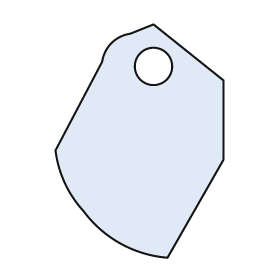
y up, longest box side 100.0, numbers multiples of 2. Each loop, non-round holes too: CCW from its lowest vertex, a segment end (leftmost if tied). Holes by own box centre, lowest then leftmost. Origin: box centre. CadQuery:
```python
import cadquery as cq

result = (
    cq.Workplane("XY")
    .moveTo(12.0, -50.0)
    .lineTo(36.0, -8.0)
    .lineTo(36.0, 26.0)
    .lineTo(6.0, 50.0)
    .lineTo(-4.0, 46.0)
    .threePointArc((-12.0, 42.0), (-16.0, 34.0))
    .lineTo(-36.0, -4.0)
    .threePointArc((-32.0, -18.0), (-24.0, -30.0))
    .threePointArc((-8.0, -44.0), (12.0, -50.0))
    .close()
    .moveTo(6.0, 32.0)
    .circle(8.0)
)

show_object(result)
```